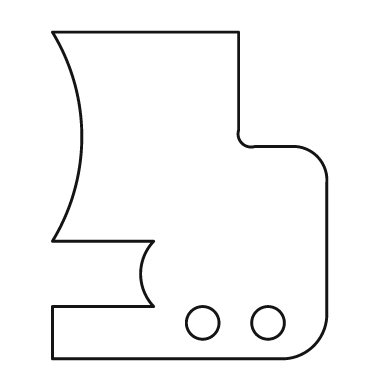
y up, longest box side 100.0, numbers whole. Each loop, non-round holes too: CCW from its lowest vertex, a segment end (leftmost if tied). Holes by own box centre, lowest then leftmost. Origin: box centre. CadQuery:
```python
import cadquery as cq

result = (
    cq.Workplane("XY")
    .moveTo(-42.0, -50.0)
    .lineTo(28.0, -50.0)
    .threePointArc((38.0, -46.0), (42.0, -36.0))
    .lineTo(42.0, 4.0)
    .threePointArc((39.0, 12.0), (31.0, 15.0))
    .lineTo(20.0, 15.0)
    .threePointArc((16.0, 16.0), (15.0, 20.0))
    .lineTo(15.0, 50.0)
    .lineTo(-42.0, 50.0)
    .threePointArc((-33.0, 18.0), (-42.0, -14.0))
    .lineTo(-11.0, -14.0)
    .threePointArc((-15.0, -24.0), (-11.0, -34.0))
    .lineTo(-42.0, -34.0)
    .close()
    .moveTo(4.0, -39.0)
    .circle(5.0)
    .moveTo(24.0, -39.0)
    .circle(5.0)
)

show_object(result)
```